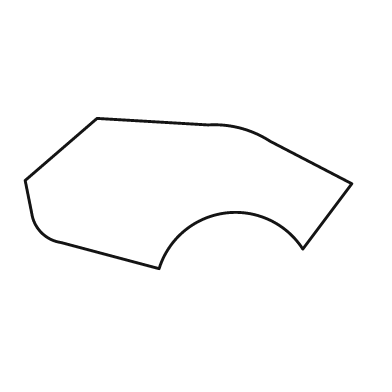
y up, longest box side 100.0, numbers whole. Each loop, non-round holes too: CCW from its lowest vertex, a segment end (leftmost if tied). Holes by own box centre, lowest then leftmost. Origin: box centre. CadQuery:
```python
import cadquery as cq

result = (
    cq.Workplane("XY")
    .moveTo(-9.0, -23.0)
    .threePointArc((11.0, -6.0), (35.0, -17.0))
    .lineTo(50.0, 3.0)
    .lineTo(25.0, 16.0)
    .threePointArc((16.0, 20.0), (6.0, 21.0))
    .lineTo(-28.0, 23.0)
    .lineTo(-50.0, 4.0)
    .lineTo(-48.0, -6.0)
    .threePointArc((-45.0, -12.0), (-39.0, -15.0))
    .close()
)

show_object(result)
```